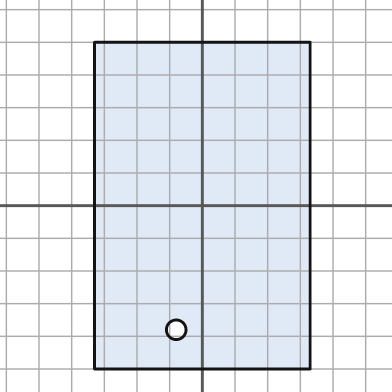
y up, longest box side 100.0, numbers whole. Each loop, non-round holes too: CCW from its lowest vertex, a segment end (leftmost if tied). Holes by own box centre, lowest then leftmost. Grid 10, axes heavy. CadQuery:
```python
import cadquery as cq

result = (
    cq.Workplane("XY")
    .moveTo(-33.0, -50.0)
    .lineTo(33.0, -50.0)
    .lineTo(33.0, 50.0)
    .lineTo(-33.0, 50.0)
    .close()
    .moveTo(-8.0, -38.0)
    .circle(3.0)
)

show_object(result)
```